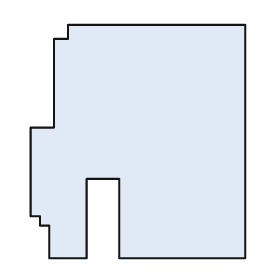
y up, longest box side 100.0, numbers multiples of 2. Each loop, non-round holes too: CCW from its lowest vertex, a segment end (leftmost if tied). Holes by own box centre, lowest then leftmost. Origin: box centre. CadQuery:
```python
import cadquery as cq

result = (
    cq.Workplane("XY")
    .moveTo(-38.0, -50.0)
    .lineTo(-22.0, -50.0)
    .lineTo(-22.0, -16.0)
    .lineTo(-8.0, -16.0)
    .lineTo(-8.0, -50.0)
    .lineTo(46.0, -50.0)
    .lineTo(46.0, 50.0)
    .lineTo(-30.0, 50.0)
    .lineTo(-30.0, 44.0)
    .lineTo(-36.0, 44.0)
    .lineTo(-36.0, 6.0)
    .lineTo(-46.0, 6.0)
    .lineTo(-46.0, -32.0)
    .lineTo(-42.0, -32.0)
    .lineTo(-42.0, -36.0)
    .lineTo(-38.0, -36.0)
    .close()
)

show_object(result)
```